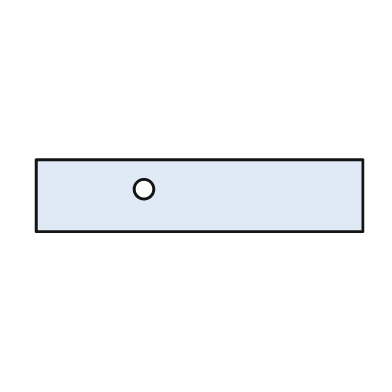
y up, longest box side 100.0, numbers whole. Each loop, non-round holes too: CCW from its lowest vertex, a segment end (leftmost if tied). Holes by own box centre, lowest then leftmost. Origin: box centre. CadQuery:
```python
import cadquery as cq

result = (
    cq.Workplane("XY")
    .moveTo(-50.0, -11.0)
    .lineTo(50.0, -11.0)
    .lineTo(50.0, 11.0)
    .lineTo(-50.0, 11.0)
    .close()
    .moveTo(-17.0, 2.0)
    .circle(3.0)
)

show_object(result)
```